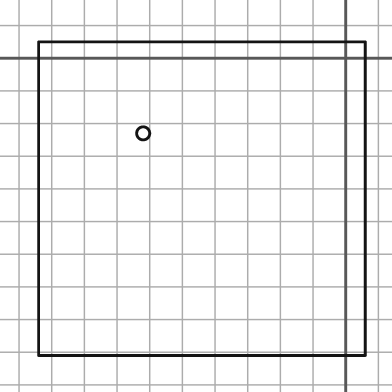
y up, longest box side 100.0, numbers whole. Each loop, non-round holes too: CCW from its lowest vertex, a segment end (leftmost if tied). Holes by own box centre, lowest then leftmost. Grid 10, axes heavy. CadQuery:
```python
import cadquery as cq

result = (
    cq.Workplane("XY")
    .moveTo(-94.0, -91.0)
    .lineTo(6.0, -91.0)
    .lineTo(6.0, 5.0)
    .lineTo(-94.0, 5.0)
    .close()
    .moveTo(-62.0, -23.0)
    .circle(2.0)
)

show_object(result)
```